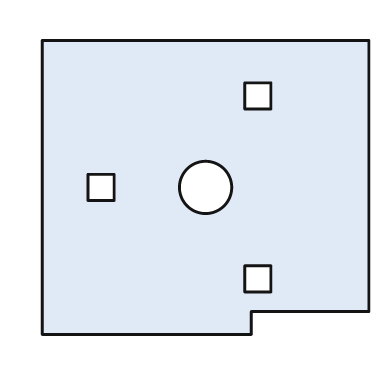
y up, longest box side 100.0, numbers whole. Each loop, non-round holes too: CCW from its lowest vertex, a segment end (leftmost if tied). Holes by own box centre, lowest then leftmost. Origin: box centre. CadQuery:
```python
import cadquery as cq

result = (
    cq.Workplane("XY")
    .moveTo(-50.0, -45.0)
    .lineTo(14.0, -45.0)
    .lineTo(14.0, -38.0)
    .lineTo(50.0, -38.0)
    .lineTo(50.0, 45.0)
    .lineTo(-50.0, 45.0)
    .close()
    .moveTo(12.0, -32.0)
    .lineTo(20.0, -32.0)
    .lineTo(20.0, -24.0)
    .lineTo(12.0, -24.0)
    .close()
    .moveTo(-36.0, -4.0)
    .lineTo(-28.0, -4.0)
    .lineTo(-28.0, 4.0)
    .lineTo(-36.0, 4.0)
    .close()
    .moveTo(0.0, 0.0)
    .circle(8.0)
    .moveTo(12.0, 24.0)
    .lineTo(20.0, 24.0)
    .lineTo(20.0, 32.0)
    .lineTo(12.0, 32.0)
    .close()
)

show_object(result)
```